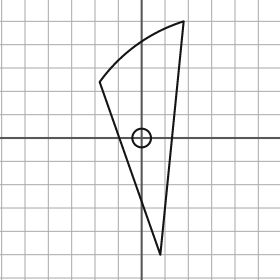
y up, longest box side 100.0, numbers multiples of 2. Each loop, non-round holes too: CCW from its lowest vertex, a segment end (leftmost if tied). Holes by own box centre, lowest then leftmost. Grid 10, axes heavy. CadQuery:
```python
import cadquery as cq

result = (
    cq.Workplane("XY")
    .moveTo(8.0, -50.0)
    .lineTo(18.0, 50.0)
    .threePointArc((-2.0, 40.0), (-18.0, 24.0))
    .close()
    .moveTo(0.0, 0.0)
    .circle(4.0)
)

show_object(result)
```